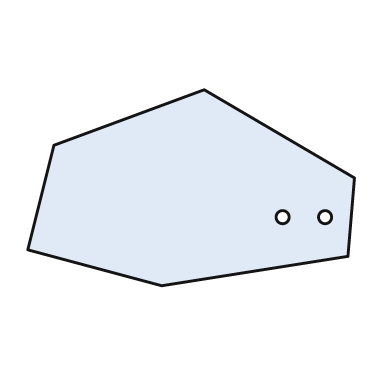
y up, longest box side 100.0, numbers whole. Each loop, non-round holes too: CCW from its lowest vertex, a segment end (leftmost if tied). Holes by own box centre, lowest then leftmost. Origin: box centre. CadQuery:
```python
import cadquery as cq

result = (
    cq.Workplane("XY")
    .moveTo(-9.0, -30.0)
    .lineTo(48.0, -21.0)
    .lineTo(50.0, 3.0)
    .lineTo(4.0, 30.0)
    .lineTo(-42.0, 13.0)
    .lineTo(-50.0, -19.0)
    .close()
    .moveTo(28.0, -9.0)
    .circle(2.0)
    .moveTo(41.0, -9.0)
    .circle(2.0)
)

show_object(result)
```